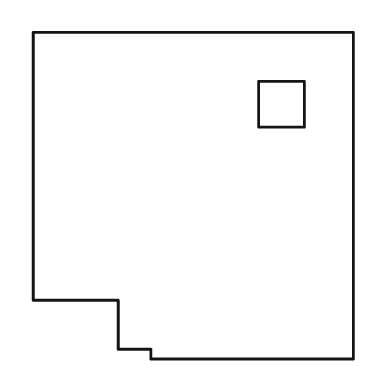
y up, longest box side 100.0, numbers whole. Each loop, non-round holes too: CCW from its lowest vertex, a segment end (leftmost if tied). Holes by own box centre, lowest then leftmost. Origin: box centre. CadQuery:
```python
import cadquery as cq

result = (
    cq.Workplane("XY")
    .moveTo(-13.0, -50.0)
    .lineTo(49.0, -50.0)
    .lineTo(49.0, 50.0)
    .lineTo(-49.0, 50.0)
    .lineTo(-49.0, -32.0)
    .lineTo(-23.0, -32.0)
    .lineTo(-23.0, -47.0)
    .lineTo(-13.0, -47.0)
    .close()
    .moveTo(20.0, 21.0)
    .lineTo(34.0, 21.0)
    .lineTo(34.0, 35.0)
    .lineTo(20.0, 35.0)
    .close()
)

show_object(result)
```